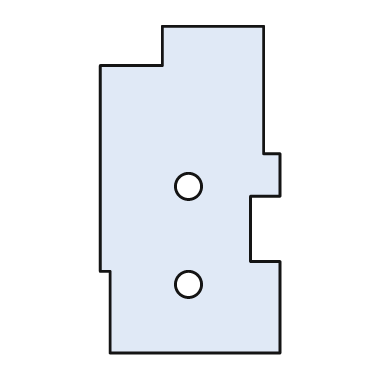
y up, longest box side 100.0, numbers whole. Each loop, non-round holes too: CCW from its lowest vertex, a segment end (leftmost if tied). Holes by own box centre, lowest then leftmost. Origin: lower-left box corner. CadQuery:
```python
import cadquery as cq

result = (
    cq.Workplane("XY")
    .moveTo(3.0, 0.0)
    .lineTo(55.0, 0.0)
    .lineTo(55.0, 28.0)
    .lineTo(46.0, 28.0)
    .lineTo(46.0, 48.0)
    .lineTo(55.0, 48.0)
    .lineTo(55.0, 61.0)
    .lineTo(50.0, 61.0)
    .lineTo(50.0, 100.0)
    .lineTo(19.0, 100.0)
    .lineTo(19.0, 88.0)
    .lineTo(0.0, 88.0)
    .lineTo(0.0, 25.0)
    .lineTo(3.0, 25.0)
    .close()
    .moveTo(27.0, 21.0)
    .circle(4.0)
    .moveTo(27.0, 51.0)
    .circle(4.0)
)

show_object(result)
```